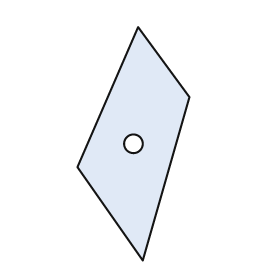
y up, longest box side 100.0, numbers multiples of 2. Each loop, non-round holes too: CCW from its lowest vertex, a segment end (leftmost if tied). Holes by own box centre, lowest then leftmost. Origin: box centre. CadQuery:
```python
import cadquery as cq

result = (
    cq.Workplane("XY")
    .moveTo(4.0, -50.0)
    .lineTo(24.0, 20.0)
    .lineTo(2.0, 50.0)
    .lineTo(-24.0, -10.0)
    .close()
    .moveTo(0.0, 0.0)
    .circle(4.0)
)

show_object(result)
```